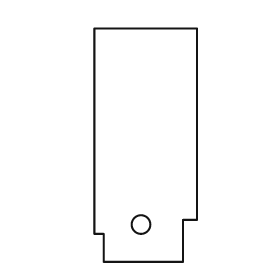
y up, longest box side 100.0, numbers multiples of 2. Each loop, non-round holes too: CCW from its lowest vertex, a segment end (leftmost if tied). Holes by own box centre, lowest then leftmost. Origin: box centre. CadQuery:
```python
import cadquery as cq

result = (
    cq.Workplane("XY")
    .moveTo(-18.0, -50.0)
    .lineTo(16.0, -50.0)
    .lineTo(16.0, -32.0)
    .lineTo(22.0, -32.0)
    .lineTo(22.0, 50.0)
    .lineTo(-22.0, 50.0)
    .lineTo(-22.0, -38.0)
    .lineTo(-18.0, -38.0)
    .close()
    .moveTo(-2.0, -34.0)
    .circle(4.0)
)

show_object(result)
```